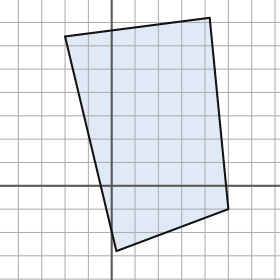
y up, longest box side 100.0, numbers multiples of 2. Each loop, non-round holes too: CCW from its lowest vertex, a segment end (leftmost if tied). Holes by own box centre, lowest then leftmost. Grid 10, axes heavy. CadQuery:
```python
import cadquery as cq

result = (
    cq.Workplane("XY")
    .moveTo(2.0, -28.0)
    .lineTo(50.0, -10.0)
    .lineTo(42.0, 72.0)
    .lineTo(-20.0, 64.0)
    .close()
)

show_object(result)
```